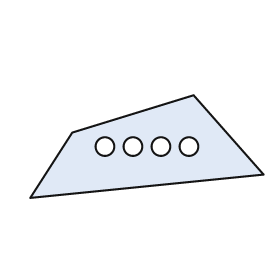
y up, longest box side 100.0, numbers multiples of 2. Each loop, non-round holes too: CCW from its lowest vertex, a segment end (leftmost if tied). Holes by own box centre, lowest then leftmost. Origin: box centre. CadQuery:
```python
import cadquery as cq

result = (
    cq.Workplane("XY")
    .moveTo(-50.0, -22.0)
    .lineTo(50.0, -12.0)
    .lineTo(20.0, 22.0)
    .lineTo(-32.0, 6.0)
    .close()
    .moveTo(-18.0, 0.0)
    .circle(4.0)
    .moveTo(-6.0, 0.0)
    .circle(4.0)
    .moveTo(6.0, 0.0)
    .circle(4.0)
    .moveTo(18.0, 0.0)
    .circle(4.0)
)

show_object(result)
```